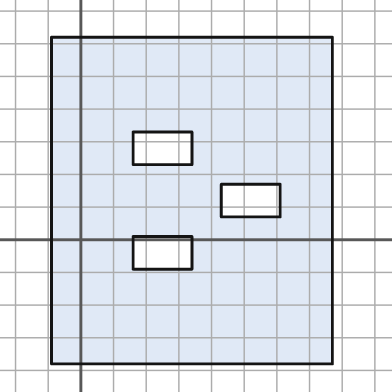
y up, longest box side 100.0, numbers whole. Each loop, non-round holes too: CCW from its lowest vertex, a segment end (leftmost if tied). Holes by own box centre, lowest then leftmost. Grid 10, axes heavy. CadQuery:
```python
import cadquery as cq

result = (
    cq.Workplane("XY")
    .moveTo(-9.0, -38.0)
    .lineTo(77.0, -38.0)
    .lineTo(77.0, 62.0)
    .lineTo(-9.0, 62.0)
    .close()
    .moveTo(16.0, -9.0)
    .lineTo(34.0, -9.0)
    .lineTo(34.0, 1.0)
    .lineTo(16.0, 1.0)
    .close()
    .moveTo(43.0, 7.0)
    .lineTo(61.0, 7.0)
    .lineTo(61.0, 17.0)
    .lineTo(43.0, 17.0)
    .close()
    .moveTo(16.0, 23.0)
    .lineTo(34.0, 23.0)
    .lineTo(34.0, 33.0)
    .lineTo(16.0, 33.0)
    .close()
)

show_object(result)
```